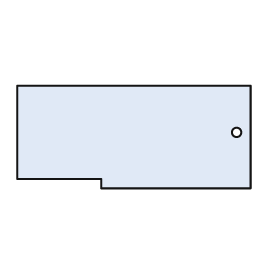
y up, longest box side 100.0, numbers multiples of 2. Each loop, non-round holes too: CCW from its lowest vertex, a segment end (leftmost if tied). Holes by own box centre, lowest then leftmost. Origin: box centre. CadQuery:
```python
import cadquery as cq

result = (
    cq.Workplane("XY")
    .moveTo(-14.0, -22.0)
    .lineTo(50.0, -22.0)
    .lineTo(50.0, 22.0)
    .lineTo(-50.0, 22.0)
    .lineTo(-50.0, -18.0)
    .lineTo(-14.0, -18.0)
    .close()
    .moveTo(44.0, 2.0)
    .circle(2.0)
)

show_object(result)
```